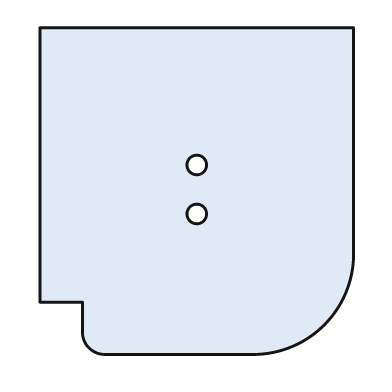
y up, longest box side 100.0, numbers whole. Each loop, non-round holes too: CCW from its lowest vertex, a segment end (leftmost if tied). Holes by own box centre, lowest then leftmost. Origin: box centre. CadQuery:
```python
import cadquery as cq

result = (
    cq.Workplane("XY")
    .moveTo(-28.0, -50.0)
    .lineTo(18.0, -50.0)
    .threePointArc((39.0, -41.0), (48.0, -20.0))
    .lineTo(48.0, 50.0)
    .lineTo(-48.0, 50.0)
    .lineTo(-48.0, -34.0)
    .lineTo(-35.0, -34.0)
    .lineTo(-35.0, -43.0)
    .threePointArc((-33.0, -48.0), (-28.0, -50.0))
    .close()
    .moveTo(0.0, -7.0)
    .circle(3.0)
    .moveTo(0.0, 8.0)
    .circle(3.0)
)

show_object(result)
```